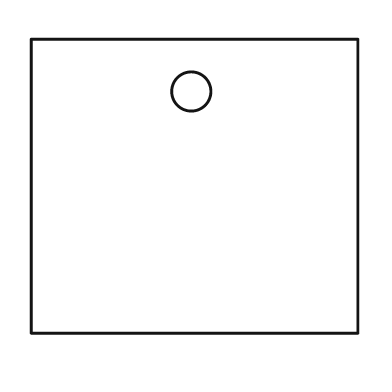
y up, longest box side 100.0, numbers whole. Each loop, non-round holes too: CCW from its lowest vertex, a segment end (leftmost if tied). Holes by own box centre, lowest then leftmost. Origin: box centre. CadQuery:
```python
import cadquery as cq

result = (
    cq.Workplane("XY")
    .moveTo(-50.0, -45.0)
    .lineTo(50.0, -45.0)
    .lineTo(50.0, 45.0)
    .lineTo(-50.0, 45.0)
    .close()
    .moveTo(-1.0, 29.0)
    .circle(6.0)
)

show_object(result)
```